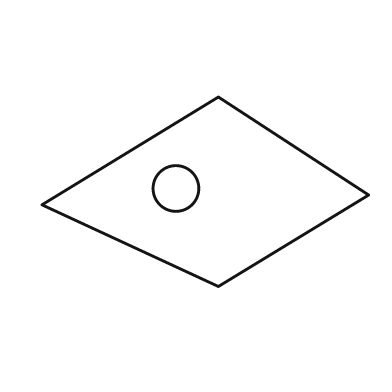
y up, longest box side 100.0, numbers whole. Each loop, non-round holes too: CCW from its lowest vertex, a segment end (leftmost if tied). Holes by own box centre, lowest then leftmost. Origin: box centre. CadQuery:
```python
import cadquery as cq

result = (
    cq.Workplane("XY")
    .moveTo(4.0, -29.0)
    .lineTo(50.0, -1.0)
    .lineTo(4.0, 29.0)
    .lineTo(-50.0, -4.0)
    .close()
    .moveTo(-9.0, 1.0)
    .circle(7.0)
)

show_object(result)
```